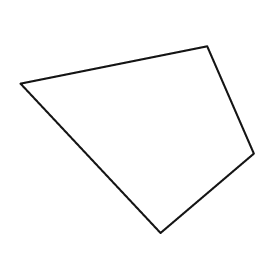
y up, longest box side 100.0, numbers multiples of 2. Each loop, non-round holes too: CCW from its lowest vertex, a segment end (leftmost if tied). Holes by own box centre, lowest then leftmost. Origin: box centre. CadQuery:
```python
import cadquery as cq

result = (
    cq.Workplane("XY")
    .moveTo(10.0, -40.0)
    .lineTo(50.0, -6.0)
    .lineTo(30.0, 40.0)
    .lineTo(-50.0, 24.0)
    .close()
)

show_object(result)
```